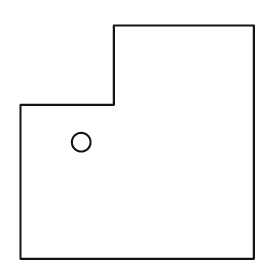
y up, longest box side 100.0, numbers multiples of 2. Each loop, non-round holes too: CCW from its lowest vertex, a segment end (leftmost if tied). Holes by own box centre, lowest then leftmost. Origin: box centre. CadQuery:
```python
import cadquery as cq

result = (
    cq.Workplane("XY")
    .moveTo(-50.0, -50.0)
    .lineTo(50.0, -50.0)
    .lineTo(50.0, 50.0)
    .lineTo(-10.0, 50.0)
    .lineTo(-10.0, 16.0)
    .lineTo(-50.0, 16.0)
    .close()
    .moveTo(-24.0, 0.0)
    .circle(4.0)
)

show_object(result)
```